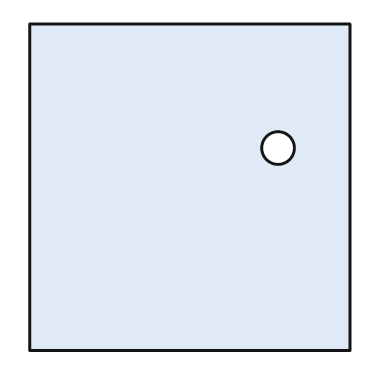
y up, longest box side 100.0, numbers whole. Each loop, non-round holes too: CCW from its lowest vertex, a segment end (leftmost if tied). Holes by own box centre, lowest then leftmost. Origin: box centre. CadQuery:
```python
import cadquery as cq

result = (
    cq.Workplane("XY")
    .moveTo(-49.0, -50.0)
    .lineTo(49.0, -50.0)
    .lineTo(49.0, 50.0)
    .lineTo(-49.0, 50.0)
    .close()
    .moveTo(27.0, 12.0)
    .circle(5.0)
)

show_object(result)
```